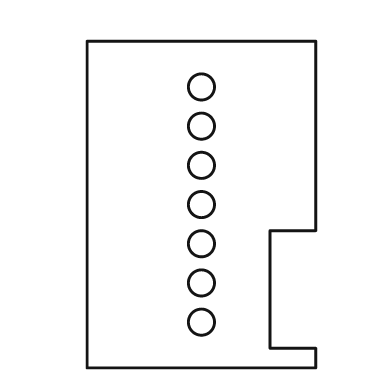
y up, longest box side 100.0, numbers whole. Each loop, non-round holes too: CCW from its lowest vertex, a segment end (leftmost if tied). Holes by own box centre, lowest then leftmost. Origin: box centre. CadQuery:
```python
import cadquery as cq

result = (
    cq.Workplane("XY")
    .moveTo(-35.0, -50.0)
    .lineTo(35.0, -50.0)
    .lineTo(35.0, -44.0)
    .lineTo(21.0, -44.0)
    .lineTo(21.0, -8.0)
    .lineTo(35.0, -8.0)
    .lineTo(35.0, 50.0)
    .lineTo(-35.0, 50.0)
    .close()
    .moveTo(0.0, -36.0)
    .circle(4.0)
    .moveTo(0.0, -24.0)
    .circle(4.0)
    .moveTo(0.0, -12.0)
    .circle(4.0)
    .moveTo(0.0, 0.0)
    .circle(4.0)
    .moveTo(0.0, 12.0)
    .circle(4.0)
    .moveTo(0.0, 24.0)
    .circle(4.0)
    .moveTo(0.0, 36.0)
    .circle(4.0)
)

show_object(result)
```